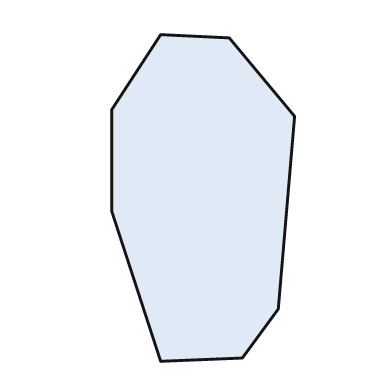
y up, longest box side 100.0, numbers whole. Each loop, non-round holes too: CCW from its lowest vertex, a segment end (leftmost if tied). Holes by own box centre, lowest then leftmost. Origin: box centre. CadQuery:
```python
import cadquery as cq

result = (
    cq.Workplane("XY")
    .moveTo(-13.0, -50.0)
    .lineTo(12.0, -49.0)
    .lineTo(23.0, -34.0)
    .lineTo(28.0, 25.0)
    .lineTo(8.0, 49.0)
    .lineTo(-13.0, 50.0)
    .lineTo(-28.0, 27.0)
    .lineTo(-28.0, -4.0)
    .close()
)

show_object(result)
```